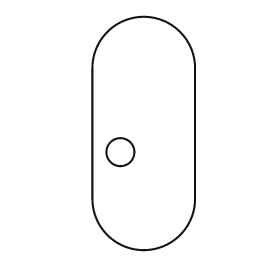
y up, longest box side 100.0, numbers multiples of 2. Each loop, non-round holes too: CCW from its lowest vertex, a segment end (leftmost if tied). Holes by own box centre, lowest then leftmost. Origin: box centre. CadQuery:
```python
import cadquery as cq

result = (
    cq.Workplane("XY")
    .moveTo(-22.0, -28.0)
    .threePointArc((0.0, -50.0), (22.0, -28.0))
    .lineTo(22.0, 28.0)
    .threePointArc((0.0, 50.0), (-22.0, 28.0))
    .close()
    .moveTo(-10.0, -8.0)
    .circle(6.0)
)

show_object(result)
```